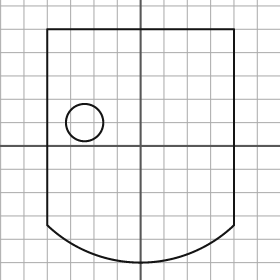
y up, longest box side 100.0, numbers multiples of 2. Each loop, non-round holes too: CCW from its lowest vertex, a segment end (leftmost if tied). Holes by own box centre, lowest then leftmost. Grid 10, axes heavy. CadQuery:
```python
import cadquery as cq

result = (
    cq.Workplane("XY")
    .moveTo(-40.0, -34.0)
    .threePointArc((0.0, -50.0), (40.0, -34.0))
    .lineTo(40.0, 50.0)
    .lineTo(-40.0, 50.0)
    .close()
    .moveTo(-24.0, 10.0)
    .circle(8.0)
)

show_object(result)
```